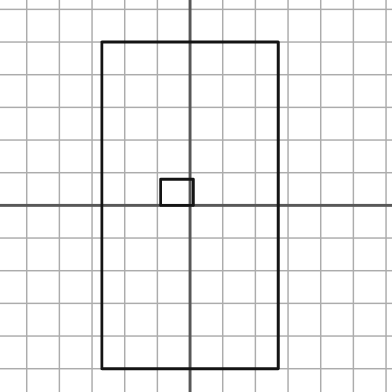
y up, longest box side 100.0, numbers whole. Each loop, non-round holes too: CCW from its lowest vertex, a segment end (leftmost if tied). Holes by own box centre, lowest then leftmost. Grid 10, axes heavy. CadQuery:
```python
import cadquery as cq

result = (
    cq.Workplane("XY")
    .moveTo(-27.0, -50.0)
    .lineTo(27.0, -50.0)
    .lineTo(27.0, 50.0)
    .lineTo(-27.0, 50.0)
    .close()
    .moveTo(-9.0, 0.0)
    .lineTo(1.0, 0.0)
    .lineTo(1.0, 8.0)
    .lineTo(-9.0, 8.0)
    .close()
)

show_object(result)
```